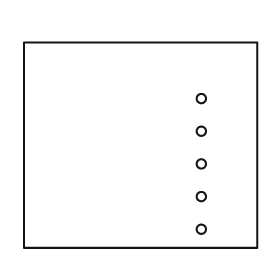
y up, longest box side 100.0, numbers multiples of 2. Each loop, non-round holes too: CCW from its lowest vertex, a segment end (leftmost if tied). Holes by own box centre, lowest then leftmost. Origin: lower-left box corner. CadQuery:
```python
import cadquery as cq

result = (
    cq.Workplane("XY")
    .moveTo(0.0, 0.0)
    .lineTo(100.0, 0.0)
    .lineTo(100.0, 88.0)
    .lineTo(0.0, 88.0)
    .close()
    .moveTo(76.0, 8.0)
    .circle(2.0)
    .moveTo(76.0, 22.0)
    .circle(2.0)
    .moveTo(76.0, 36.0)
    .circle(2.0)
    .moveTo(76.0, 50.0)
    .circle(2.0)
    .moveTo(76.0, 64.0)
    .circle(2.0)
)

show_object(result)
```